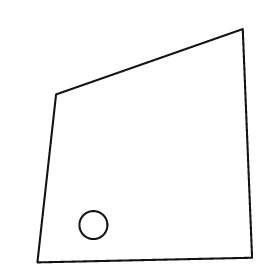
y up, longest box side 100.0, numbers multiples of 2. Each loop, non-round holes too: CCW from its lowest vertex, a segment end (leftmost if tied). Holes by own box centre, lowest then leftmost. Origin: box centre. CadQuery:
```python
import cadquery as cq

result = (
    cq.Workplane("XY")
    .moveTo(-46.0, -50.0)
    .lineTo(46.0, -48.0)
    .lineTo(42.0, 50.0)
    .lineTo(-38.0, 22.0)
    .close()
    .moveTo(-22.0, -34.0)
    .circle(6.0)
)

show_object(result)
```